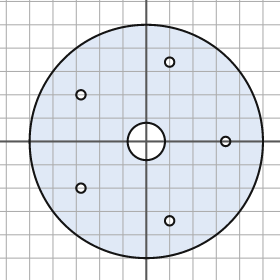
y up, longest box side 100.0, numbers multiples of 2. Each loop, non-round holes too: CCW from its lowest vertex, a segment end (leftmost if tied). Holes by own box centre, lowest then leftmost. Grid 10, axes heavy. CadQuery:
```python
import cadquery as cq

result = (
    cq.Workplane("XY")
    .moveTo(0.0, 0.0)
    .circle(50.0)
    .moveTo(10.0, -34.0)
    .circle(2.0)
    .moveTo(-28.0, -20.0)
    .circle(2.0)
    .moveTo(0.0, 0.0)
    .circle(8.0)
    .moveTo(34.0, 0.0)
    .circle(2.0)
    .moveTo(-28.0, 20.0)
    .circle(2.0)
    .moveTo(10.0, 34.0)
    .circle(2.0)
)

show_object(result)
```